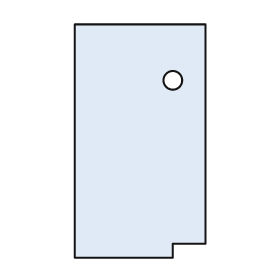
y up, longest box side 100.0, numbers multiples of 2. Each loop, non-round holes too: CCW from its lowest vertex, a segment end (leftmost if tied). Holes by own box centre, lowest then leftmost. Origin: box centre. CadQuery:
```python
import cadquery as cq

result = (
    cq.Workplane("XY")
    .moveTo(-28.0, -50.0)
    .lineTo(14.0, -50.0)
    .lineTo(14.0, -44.0)
    .lineTo(28.0, -44.0)
    .lineTo(28.0, 50.0)
    .lineTo(-28.0, 50.0)
    .close()
    .moveTo(14.0, 26.0)
    .circle(4.0)
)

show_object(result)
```